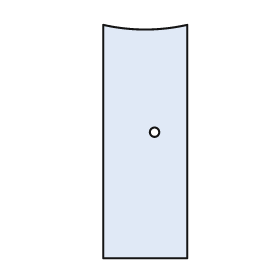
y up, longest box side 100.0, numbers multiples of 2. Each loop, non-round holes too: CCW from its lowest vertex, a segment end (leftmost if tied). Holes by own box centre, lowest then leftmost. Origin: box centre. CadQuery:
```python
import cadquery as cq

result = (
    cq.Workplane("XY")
    .moveTo(-18.0, -50.0)
    .lineTo(18.0, -50.0)
    .lineTo(18.0, 50.0)
    .threePointArc((0.0, 48.0), (-18.0, 50.0))
    .close()
    .moveTo(4.0, 4.0)
    .circle(2.0)
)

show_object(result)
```